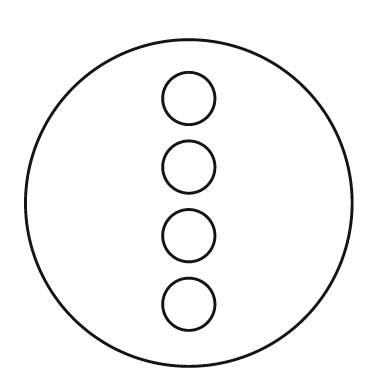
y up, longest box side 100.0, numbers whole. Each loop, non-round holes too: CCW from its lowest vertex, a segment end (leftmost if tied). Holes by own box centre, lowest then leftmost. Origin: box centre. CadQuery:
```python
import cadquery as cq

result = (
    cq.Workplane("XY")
    .moveTo(0.0, 0.0)
    .circle(50.0)
    .moveTo(0.0, -31.0)
    .circle(8.0)
    .moveTo(0.0, -10.0)
    .circle(8.0)
    .moveTo(0.0, 11.0)
    .circle(8.0)
    .moveTo(0.0, 32.0)
    .circle(8.0)
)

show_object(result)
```